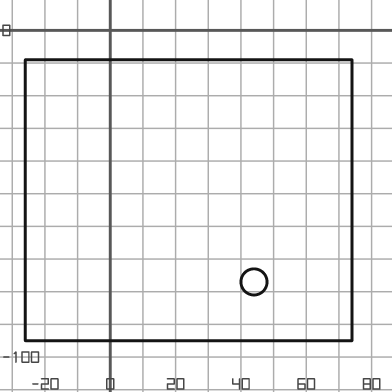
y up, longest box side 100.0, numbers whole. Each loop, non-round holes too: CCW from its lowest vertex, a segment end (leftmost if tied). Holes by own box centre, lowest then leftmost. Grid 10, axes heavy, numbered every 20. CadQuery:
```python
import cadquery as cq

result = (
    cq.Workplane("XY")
    .moveTo(-26.0, -95.0)
    .lineTo(74.0, -95.0)
    .lineTo(74.0, -9.0)
    .lineTo(-26.0, -9.0)
    .close()
    .moveTo(44.0, -77.0)
    .circle(4.0)
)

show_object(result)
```